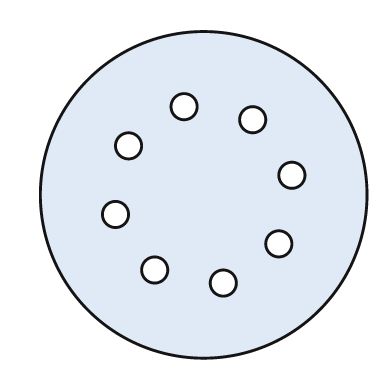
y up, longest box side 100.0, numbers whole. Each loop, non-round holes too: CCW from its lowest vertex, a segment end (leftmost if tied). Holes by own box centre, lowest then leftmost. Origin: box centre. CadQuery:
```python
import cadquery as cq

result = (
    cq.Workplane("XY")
    .moveTo(0.0, 0.0)
    .circle(50.0)
    .moveTo(6.0, -27.0)
    .circle(4.0)
    .moveTo(-15.0, -23.0)
    .circle(4.0)
    .moveTo(23.0, -15.0)
    .circle(4.0)
    .moveTo(-27.0, -6.0)
    .circle(4.0)
    .moveTo(27.0, 6.0)
    .circle(4.0)
    .moveTo(-23.0, 15.0)
    .circle(4.0)
    .moveTo(15.0, 23.0)
    .circle(4.0)
    .moveTo(-6.0, 27.0)
    .circle(4.0)
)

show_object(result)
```